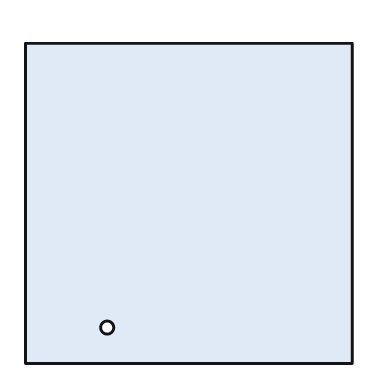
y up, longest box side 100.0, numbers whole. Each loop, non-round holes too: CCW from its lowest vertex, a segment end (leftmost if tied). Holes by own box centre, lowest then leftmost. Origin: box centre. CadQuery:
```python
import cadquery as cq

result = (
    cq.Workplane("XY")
    .moveTo(-50.0, -49.0)
    .lineTo(50.0, -49.0)
    .lineTo(50.0, 49.0)
    .lineTo(-50.0, 49.0)
    .close()
    .moveTo(-25.0, -38.0)
    .circle(2.0)
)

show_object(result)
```